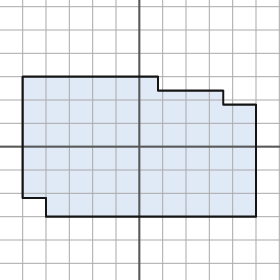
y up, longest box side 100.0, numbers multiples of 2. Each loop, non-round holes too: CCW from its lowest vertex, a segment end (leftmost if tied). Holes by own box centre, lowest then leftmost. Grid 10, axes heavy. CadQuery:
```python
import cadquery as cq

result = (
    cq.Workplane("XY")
    .moveTo(-40.0, -30.0)
    .lineTo(50.0, -30.0)
    .lineTo(50.0, 18.0)
    .lineTo(36.0, 18.0)
    .lineTo(36.0, 24.0)
    .lineTo(8.0, 24.0)
    .lineTo(8.0, 30.0)
    .lineTo(-50.0, 30.0)
    .lineTo(-50.0, -22.0)
    .lineTo(-40.0, -22.0)
    .close()
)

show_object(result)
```